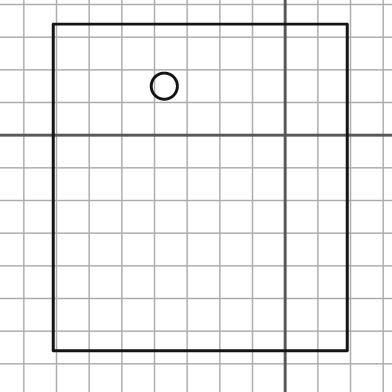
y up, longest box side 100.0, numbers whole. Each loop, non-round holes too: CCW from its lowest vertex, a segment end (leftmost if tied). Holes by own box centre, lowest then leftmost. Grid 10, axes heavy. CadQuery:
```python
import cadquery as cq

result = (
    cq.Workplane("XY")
    .moveTo(-71.0, -66.0)
    .lineTo(19.0, -66.0)
    .lineTo(19.0, 34.0)
    .lineTo(-71.0, 34.0)
    .close()
    .moveTo(-37.0, 15.0)
    .circle(4.0)
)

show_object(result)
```